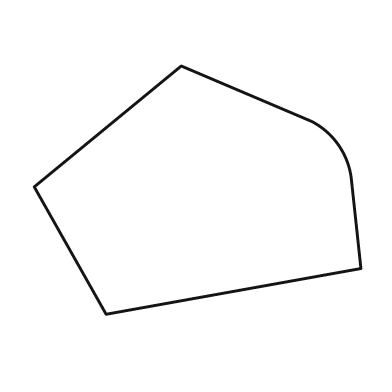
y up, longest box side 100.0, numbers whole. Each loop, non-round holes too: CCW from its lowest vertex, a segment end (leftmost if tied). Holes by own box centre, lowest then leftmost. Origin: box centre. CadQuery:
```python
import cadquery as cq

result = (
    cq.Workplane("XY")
    .moveTo(-28.0, -38.0)
    .lineTo(50.0, -24.0)
    .lineTo(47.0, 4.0)
    .threePointArc((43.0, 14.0), (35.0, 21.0))
    .lineTo(-5.0, 38.0)
    .lineTo(-50.0, 1.0)
    .close()
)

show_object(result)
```